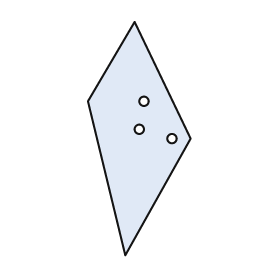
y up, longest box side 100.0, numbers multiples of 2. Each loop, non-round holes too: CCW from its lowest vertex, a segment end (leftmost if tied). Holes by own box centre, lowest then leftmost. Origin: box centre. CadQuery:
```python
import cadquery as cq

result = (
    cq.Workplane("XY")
    .moveTo(-6.0, -50.0)
    .lineTo(22.0, 0.0)
    .lineTo(-2.0, 50.0)
    .lineTo(-22.0, 16.0)
    .close()
    .moveTo(14.0, 0.0)
    .circle(2.0)
    .moveTo(0.0, 4.0)
    .circle(2.0)
    .moveTo(2.0, 16.0)
    .circle(2.0)
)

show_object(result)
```